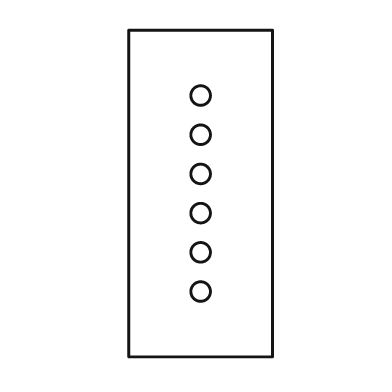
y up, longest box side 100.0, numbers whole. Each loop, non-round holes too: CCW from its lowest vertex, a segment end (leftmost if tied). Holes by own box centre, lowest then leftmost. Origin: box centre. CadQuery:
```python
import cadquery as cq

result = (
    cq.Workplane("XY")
    .moveTo(-22.0, -50.0)
    .lineTo(22.0, -50.0)
    .lineTo(22.0, 50.0)
    .lineTo(-22.0, 50.0)
    .close()
    .moveTo(0.0, -30.0)
    .circle(3.0)
    .moveTo(0.0, -18.0)
    .circle(3.0)
    .moveTo(0.0, -6.0)
    .circle(3.0)
    .moveTo(0.0, 6.0)
    .circle(3.0)
    .moveTo(0.0, 18.0)
    .circle(3.0)
    .moveTo(0.0, 30.0)
    .circle(3.0)
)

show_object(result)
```